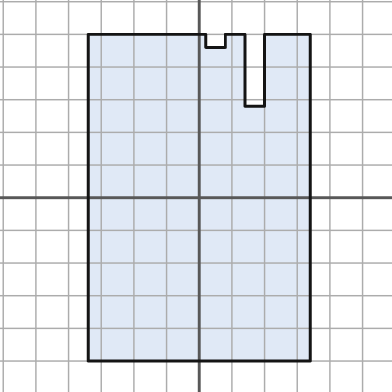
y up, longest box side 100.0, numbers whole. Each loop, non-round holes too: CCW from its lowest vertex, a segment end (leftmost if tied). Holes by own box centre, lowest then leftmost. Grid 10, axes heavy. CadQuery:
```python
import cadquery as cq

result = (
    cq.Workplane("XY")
    .moveTo(-34.0, -50.0)
    .lineTo(34.0, -50.0)
    .lineTo(34.0, 50.0)
    .lineTo(20.0, 50.0)
    .lineTo(20.0, 28.0)
    .lineTo(14.0, 28.0)
    .lineTo(14.0, 50.0)
    .lineTo(8.0, 50.0)
    .lineTo(8.0, 46.0)
    .lineTo(2.0, 46.0)
    .lineTo(2.0, 50.0)
    .lineTo(-34.0, 50.0)
    .close()
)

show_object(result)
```